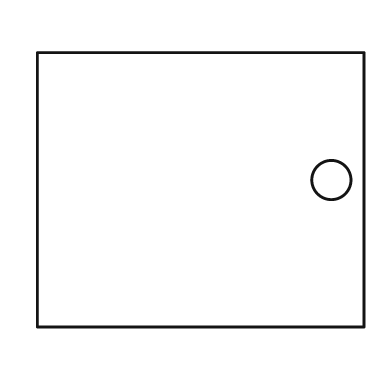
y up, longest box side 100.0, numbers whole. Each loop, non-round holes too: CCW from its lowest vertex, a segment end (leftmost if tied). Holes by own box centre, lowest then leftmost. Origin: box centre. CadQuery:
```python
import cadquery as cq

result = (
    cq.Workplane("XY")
    .moveTo(-50.0, -42.0)
    .lineTo(50.0, -42.0)
    .lineTo(50.0, 42.0)
    .lineTo(-50.0, 42.0)
    .close()
    .moveTo(40.0, 3.0)
    .circle(6.0)
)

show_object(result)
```